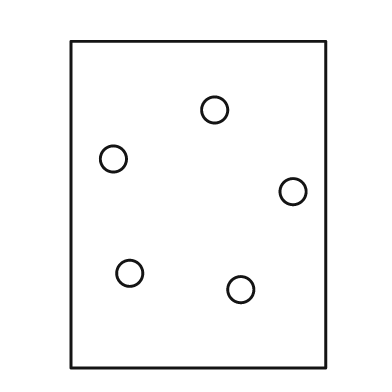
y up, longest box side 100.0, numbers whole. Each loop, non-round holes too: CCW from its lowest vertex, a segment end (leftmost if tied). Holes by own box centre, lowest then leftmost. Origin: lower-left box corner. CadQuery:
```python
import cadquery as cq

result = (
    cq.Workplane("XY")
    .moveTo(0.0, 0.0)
    .lineTo(78.0, 0.0)
    .lineTo(78.0, 100.0)
    .lineTo(0.0, 100.0)
    .close()
    .moveTo(52.0, 24.0)
    .circle(4.0)
    .moveTo(18.0, 29.0)
    .circle(4.0)
    .moveTo(68.0, 54.0)
    .circle(4.0)
    .moveTo(13.0, 64.0)
    .circle(4.0)
    .moveTo(44.0, 79.0)
    .circle(4.0)
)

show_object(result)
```